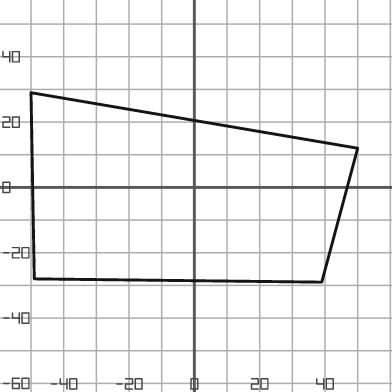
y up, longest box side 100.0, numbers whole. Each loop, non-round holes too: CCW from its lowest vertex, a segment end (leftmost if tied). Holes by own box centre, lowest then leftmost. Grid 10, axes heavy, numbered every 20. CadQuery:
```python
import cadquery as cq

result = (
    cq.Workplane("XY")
    .moveTo(39.0, -29.0)
    .lineTo(50.0, 12.0)
    .lineTo(-50.0, 29.0)
    .lineTo(-49.0, -28.0)
    .close()
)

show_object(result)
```